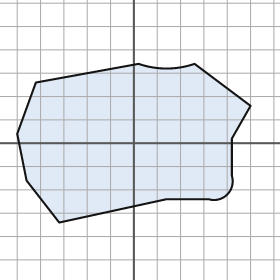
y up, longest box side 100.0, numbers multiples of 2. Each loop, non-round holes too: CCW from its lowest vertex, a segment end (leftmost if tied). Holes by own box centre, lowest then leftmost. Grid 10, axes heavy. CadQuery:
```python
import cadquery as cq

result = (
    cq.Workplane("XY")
    .moveTo(-32.0, -34.0)
    .lineTo(14.0, -24.0)
    .lineTo(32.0, -24.0)
    .threePointArc((40.0, -22.0), (42.0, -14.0))
    .lineTo(42.0, 2.0)
    .lineTo(50.0, 16.0)
    .lineTo(26.0, 34.0)
    .threePointArc((14.0, 32.0), (2.0, 34.0))
    .lineTo(-42.0, 26.0)
    .lineTo(-50.0, 4.0)
    .lineTo(-46.0, -16.0)
    .close()
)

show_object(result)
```